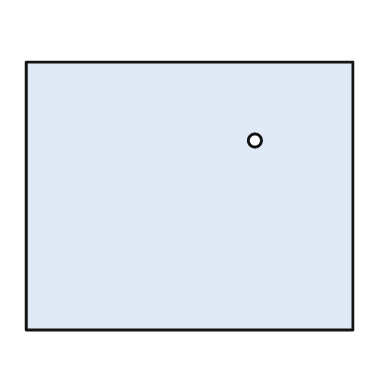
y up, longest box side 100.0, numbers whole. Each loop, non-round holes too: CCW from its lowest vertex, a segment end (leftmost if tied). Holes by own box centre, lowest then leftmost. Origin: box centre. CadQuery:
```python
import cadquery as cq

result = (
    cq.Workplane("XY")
    .moveTo(-50.0, -41.0)
    .lineTo(50.0, -41.0)
    .lineTo(50.0, 41.0)
    .lineTo(-50.0, 41.0)
    .close()
    .moveTo(20.0, 17.0)
    .circle(2.0)
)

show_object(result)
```